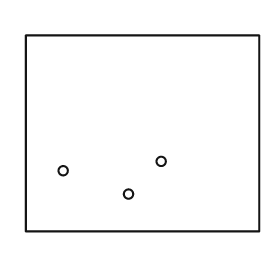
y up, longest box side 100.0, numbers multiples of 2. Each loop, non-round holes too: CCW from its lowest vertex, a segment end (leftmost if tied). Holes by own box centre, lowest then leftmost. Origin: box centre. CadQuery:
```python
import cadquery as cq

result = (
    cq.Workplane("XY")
    .moveTo(-50.0, -42.0)
    .lineTo(50.0, -42.0)
    .lineTo(50.0, 42.0)
    .lineTo(-50.0, 42.0)
    .close()
    .moveTo(-6.0, -26.0)
    .circle(2.0)
    .moveTo(-34.0, -16.0)
    .circle(2.0)
    .moveTo(8.0, -12.0)
    .circle(2.0)
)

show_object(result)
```